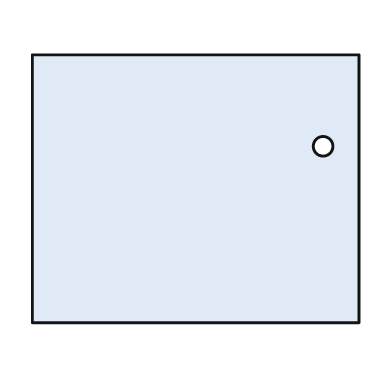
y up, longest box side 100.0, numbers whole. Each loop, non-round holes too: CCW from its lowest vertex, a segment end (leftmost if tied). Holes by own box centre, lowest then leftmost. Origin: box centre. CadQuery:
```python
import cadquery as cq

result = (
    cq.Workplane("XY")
    .moveTo(-50.0, -41.0)
    .lineTo(50.0, -41.0)
    .lineTo(50.0, 41.0)
    .lineTo(-50.0, 41.0)
    .close()
    .moveTo(39.0, 13.0)
    .circle(3.0)
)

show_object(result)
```